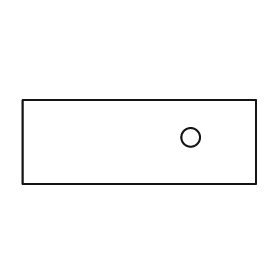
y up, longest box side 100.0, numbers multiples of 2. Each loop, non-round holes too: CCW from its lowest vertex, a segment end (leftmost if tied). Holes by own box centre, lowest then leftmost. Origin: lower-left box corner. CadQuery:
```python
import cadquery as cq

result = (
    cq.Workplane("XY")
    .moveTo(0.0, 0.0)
    .lineTo(100.0, 0.0)
    .lineTo(100.0, 36.0)
    .lineTo(0.0, 36.0)
    .close()
    .moveTo(72.0, 20.0)
    .circle(4.0)
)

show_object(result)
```